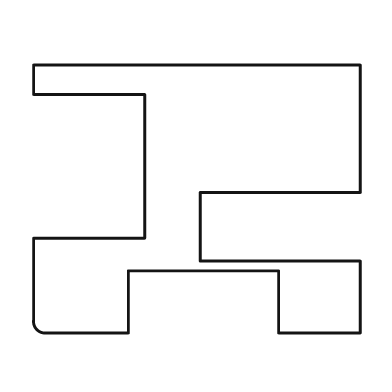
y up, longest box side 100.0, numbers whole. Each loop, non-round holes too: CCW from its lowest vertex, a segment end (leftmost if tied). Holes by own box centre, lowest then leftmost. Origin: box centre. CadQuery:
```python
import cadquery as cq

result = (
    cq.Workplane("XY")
    .moveTo(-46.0, -41.0)
    .lineTo(-21.0, -41.0)
    .lineTo(-21.0, -22.0)
    .lineTo(25.0, -22.0)
    .lineTo(25.0, -41.0)
    .lineTo(50.0, -41.0)
    .lineTo(50.0, -19.0)
    .lineTo(1.0, -19.0)
    .lineTo(1.0, 2.0)
    .lineTo(50.0, 2.0)
    .lineTo(50.0, 41.0)
    .lineTo(-50.0, 41.0)
    .lineTo(-50.0, 32.0)
    .lineTo(-16.0, 32.0)
    .lineTo(-16.0, -12.0)
    .lineTo(-50.0, -12.0)
    .lineTo(-50.0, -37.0)
    .threePointArc((-49.0, -40.0), (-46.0, -41.0))
    .close()
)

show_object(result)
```